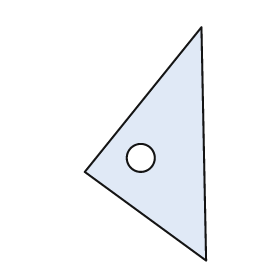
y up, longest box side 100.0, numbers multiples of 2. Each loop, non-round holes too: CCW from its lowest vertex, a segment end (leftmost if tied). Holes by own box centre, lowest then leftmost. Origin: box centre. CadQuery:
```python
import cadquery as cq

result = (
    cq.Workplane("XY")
    .moveTo(26.0, -50.0)
    .lineTo(24.0, 50.0)
    .lineTo(-26.0, -12.0)
    .close()
    .moveTo(-2.0, -6.0)
    .circle(6.0)
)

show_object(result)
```